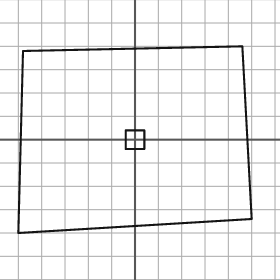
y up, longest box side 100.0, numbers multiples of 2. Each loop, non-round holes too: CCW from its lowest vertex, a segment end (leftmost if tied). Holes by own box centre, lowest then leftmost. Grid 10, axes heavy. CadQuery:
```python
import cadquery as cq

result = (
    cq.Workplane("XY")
    .moveTo(-50.0, -40.0)
    .lineTo(50.0, -34.0)
    .lineTo(46.0, 40.0)
    .lineTo(-48.0, 38.0)
    .close()
    .moveTo(-4.0, -4.0)
    .lineTo(4.0, -4.0)
    .lineTo(4.0, 4.0)
    .lineTo(-4.0, 4.0)
    .close()
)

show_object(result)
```